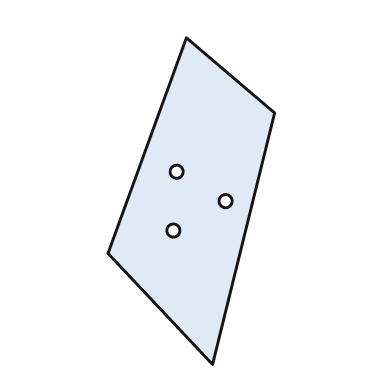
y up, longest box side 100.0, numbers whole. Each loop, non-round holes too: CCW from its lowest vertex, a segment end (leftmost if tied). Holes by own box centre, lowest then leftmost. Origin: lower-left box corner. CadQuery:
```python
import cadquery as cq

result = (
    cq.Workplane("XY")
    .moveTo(32.0, 0.0)
    .lineTo(51.0, 77.0)
    .lineTo(24.0, 100.0)
    .lineTo(0.0, 34.0)
    .close()
    .moveTo(20.0, 41.0)
    .circle(2.0)
    .moveTo(36.0, 50.0)
    .circle(2.0)
    .moveTo(21.0, 59.0)
    .circle(2.0)
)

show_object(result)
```